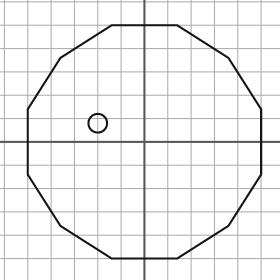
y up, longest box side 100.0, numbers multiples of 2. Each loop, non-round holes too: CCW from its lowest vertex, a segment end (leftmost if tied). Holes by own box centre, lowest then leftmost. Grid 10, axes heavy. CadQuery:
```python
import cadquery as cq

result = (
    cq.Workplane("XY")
    .moveTo(-14.0, -50.0)
    .lineTo(14.0, -50.0)
    .lineTo(36.0, -36.0)
    .lineTo(50.0, -14.0)
    .lineTo(50.0, 14.0)
    .lineTo(36.0, 36.0)
    .lineTo(14.0, 50.0)
    .lineTo(-14.0, 50.0)
    .lineTo(-36.0, 36.0)
    .lineTo(-50.0, 14.0)
    .lineTo(-50.0, -14.0)
    .lineTo(-36.0, -36.0)
    .close()
    .moveTo(-20.0, 8.0)
    .circle(4.0)
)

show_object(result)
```